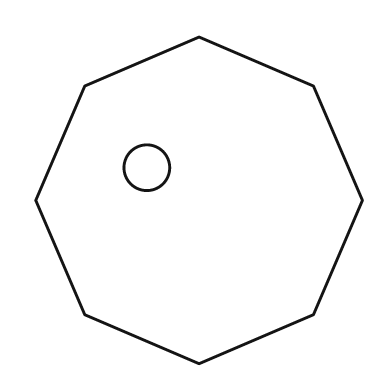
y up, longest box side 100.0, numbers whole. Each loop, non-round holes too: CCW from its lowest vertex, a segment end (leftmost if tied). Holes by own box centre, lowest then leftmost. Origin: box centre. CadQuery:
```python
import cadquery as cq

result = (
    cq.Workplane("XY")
    .moveTo(0.0, -50.0)
    .lineTo(35.0, -35.0)
    .lineTo(50.0, 0.0)
    .lineTo(35.0, 35.0)
    .lineTo(0.0, 50.0)
    .lineTo(-35.0, 35.0)
    .lineTo(-50.0, 0.0)
    .lineTo(-35.0, -35.0)
    .close()
    .moveTo(-16.0, 10.0)
    .circle(7.0)
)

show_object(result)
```